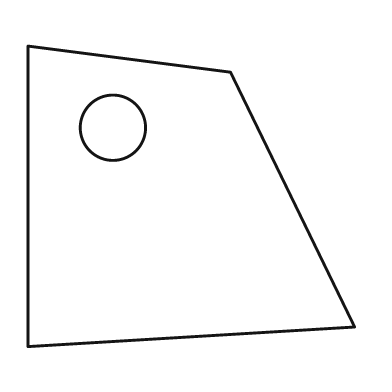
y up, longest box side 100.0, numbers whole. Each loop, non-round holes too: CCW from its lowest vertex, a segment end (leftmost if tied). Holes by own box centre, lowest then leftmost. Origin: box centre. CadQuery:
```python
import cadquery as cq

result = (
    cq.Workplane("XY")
    .moveTo(-50.0, -46.0)
    .lineTo(50.0, -40.0)
    .lineTo(12.0, 38.0)
    .lineTo(-50.0, 46.0)
    .close()
    .moveTo(-24.0, 21.0)
    .circle(10.0)
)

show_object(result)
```